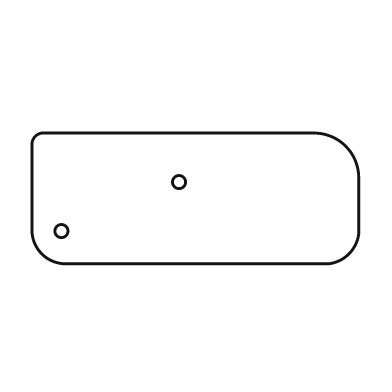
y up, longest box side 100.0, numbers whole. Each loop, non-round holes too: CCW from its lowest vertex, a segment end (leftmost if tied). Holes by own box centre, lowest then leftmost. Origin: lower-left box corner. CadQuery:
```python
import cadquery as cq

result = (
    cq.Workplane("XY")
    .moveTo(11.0, 0.0)
    .lineTo(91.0, 0.0)
    .threePointArc((97.0, 3.0), (100.0, 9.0))
    .lineTo(100.0, 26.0)
    .threePointArc((96.0, 36.0), (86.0, 40.0))
    .lineTo(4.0, 40.0)
    .threePointArc((1.0, 39.0), (0.0, 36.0))
    .lineTo(0.0, 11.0)
    .threePointArc((3.0, 3.0), (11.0, 0.0))
    .close()
    .moveTo(9.0, 10.0)
    .circle(2.0)
    .moveTo(45.0, 25.0)
    .circle(2.0)
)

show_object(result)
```